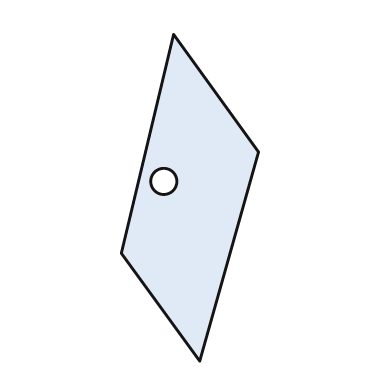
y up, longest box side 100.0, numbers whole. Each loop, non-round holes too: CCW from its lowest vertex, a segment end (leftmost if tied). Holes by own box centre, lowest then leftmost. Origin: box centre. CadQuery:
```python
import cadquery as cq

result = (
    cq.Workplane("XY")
    .moveTo(3.0, -50.0)
    .lineTo(21.0, 14.0)
    .lineTo(-5.0, 50.0)
    .lineTo(-21.0, -17.0)
    .close()
    .moveTo(-8.0, 5.0)
    .circle(4.0)
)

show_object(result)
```